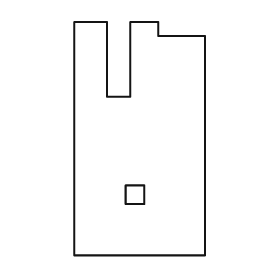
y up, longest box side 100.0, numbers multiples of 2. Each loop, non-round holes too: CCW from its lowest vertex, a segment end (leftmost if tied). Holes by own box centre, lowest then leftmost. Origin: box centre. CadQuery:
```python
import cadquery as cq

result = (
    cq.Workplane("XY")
    .moveTo(-28.0, -50.0)
    .lineTo(28.0, -50.0)
    .lineTo(28.0, 44.0)
    .lineTo(8.0, 44.0)
    .lineTo(8.0, 50.0)
    .lineTo(-4.0, 50.0)
    .lineTo(-4.0, 18.0)
    .lineTo(-14.0, 18.0)
    .lineTo(-14.0, 50.0)
    .lineTo(-28.0, 50.0)
    .close()
    .moveTo(-6.0, -28.0)
    .lineTo(2.0, -28.0)
    .lineTo(2.0, -20.0)
    .lineTo(-6.0, -20.0)
    .close()
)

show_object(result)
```